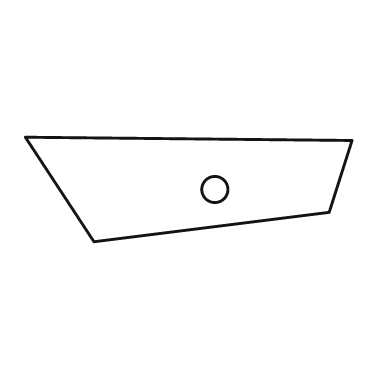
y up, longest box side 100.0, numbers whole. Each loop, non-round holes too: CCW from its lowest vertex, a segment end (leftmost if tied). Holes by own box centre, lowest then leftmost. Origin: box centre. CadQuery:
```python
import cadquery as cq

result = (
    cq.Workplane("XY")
    .moveTo(-29.0, -16.0)
    .lineTo(43.0, -7.0)
    .lineTo(50.0, 15.0)
    .lineTo(-50.0, 16.0)
    .close()
    .moveTo(8.0, 0.0)
    .circle(4.0)
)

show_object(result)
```